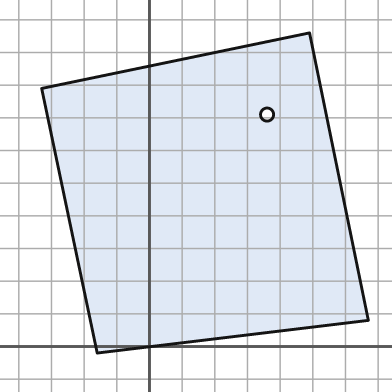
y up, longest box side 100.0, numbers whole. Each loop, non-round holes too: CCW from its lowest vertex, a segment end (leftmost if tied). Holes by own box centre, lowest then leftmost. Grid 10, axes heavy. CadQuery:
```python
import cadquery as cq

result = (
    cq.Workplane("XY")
    .moveTo(-16.0, -2.0)
    .lineTo(67.0, 8.0)
    .lineTo(49.0, 96.0)
    .lineTo(-33.0, 79.0)
    .close()
    .moveTo(36.0, 71.0)
    .circle(2.0)
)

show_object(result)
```